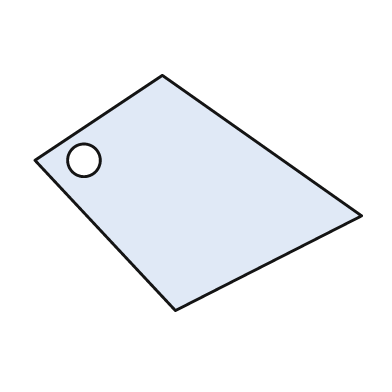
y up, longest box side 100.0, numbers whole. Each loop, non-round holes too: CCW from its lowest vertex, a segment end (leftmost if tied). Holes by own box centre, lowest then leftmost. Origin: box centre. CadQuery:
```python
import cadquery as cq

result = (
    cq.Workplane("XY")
    .moveTo(-7.0, -36.0)
    .lineTo(50.0, -7.0)
    .lineTo(-11.0, 36.0)
    .lineTo(-50.0, 10.0)
    .close()
    .moveTo(-35.0, 10.0)
    .circle(5.0)
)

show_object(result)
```